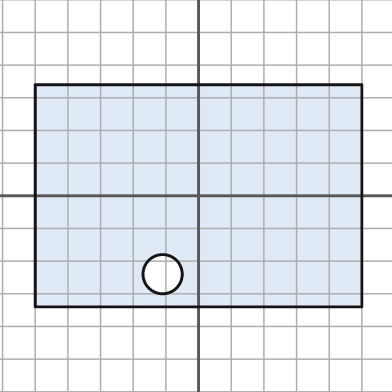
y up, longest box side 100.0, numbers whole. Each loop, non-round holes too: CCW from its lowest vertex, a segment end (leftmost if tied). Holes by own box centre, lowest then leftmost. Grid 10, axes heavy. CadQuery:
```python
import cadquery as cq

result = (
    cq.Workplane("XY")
    .moveTo(-50.0, -34.0)
    .lineTo(50.0, -34.0)
    .lineTo(50.0, 34.0)
    .lineTo(-50.0, 34.0)
    .close()
    .moveTo(-11.0, -24.0)
    .circle(6.0)
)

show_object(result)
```